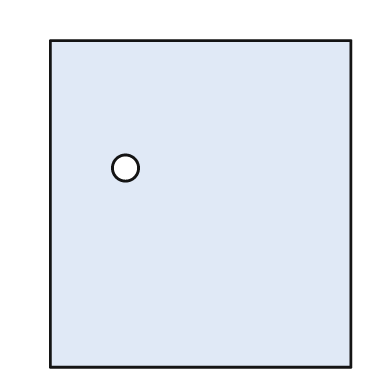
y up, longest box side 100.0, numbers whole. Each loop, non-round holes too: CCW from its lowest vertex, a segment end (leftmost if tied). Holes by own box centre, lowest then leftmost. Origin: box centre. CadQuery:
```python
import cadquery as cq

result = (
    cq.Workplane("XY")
    .moveTo(-46.0, -50.0)
    .lineTo(46.0, -50.0)
    .lineTo(46.0, 50.0)
    .lineTo(-46.0, 50.0)
    .close()
    .moveTo(-23.0, 11.0)
    .circle(4.0)
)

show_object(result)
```